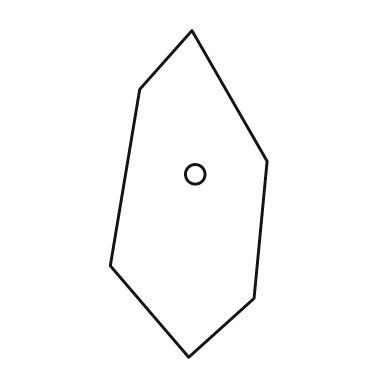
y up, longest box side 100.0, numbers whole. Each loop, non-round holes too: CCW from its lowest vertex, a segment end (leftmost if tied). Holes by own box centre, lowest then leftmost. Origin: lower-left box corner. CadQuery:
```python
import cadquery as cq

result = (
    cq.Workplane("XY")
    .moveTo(24.0, 0.0)
    .lineTo(44.0, 18.0)
    .lineTo(48.0, 60.0)
    .lineTo(25.0, 100.0)
    .lineTo(9.0, 82.0)
    .lineTo(0.0, 28.0)
    .close()
    .moveTo(26.0, 56.0)
    .circle(3.0)
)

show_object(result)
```